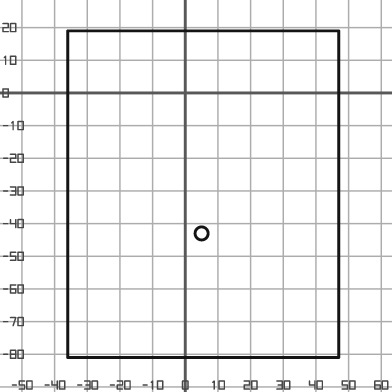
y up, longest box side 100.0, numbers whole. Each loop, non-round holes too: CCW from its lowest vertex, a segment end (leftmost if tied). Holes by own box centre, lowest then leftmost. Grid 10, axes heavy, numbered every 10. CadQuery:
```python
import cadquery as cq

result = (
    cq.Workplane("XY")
    .moveTo(-36.0, -81.0)
    .lineTo(47.0, -81.0)
    .lineTo(47.0, 19.0)
    .lineTo(-36.0, 19.0)
    .close()
    .moveTo(5.0, -43.0)
    .circle(2.0)
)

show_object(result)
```